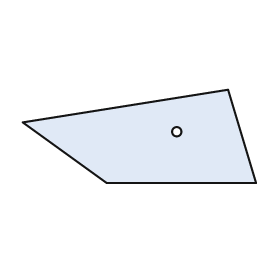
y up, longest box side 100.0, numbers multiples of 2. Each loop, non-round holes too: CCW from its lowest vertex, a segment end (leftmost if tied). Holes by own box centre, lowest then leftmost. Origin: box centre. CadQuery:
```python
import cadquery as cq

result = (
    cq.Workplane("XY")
    .moveTo(-14.0, -20.0)
    .lineTo(50.0, -20.0)
    .lineTo(38.0, 20.0)
    .lineTo(-50.0, 6.0)
    .close()
    .moveTo(16.0, 2.0)
    .circle(2.0)
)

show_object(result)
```